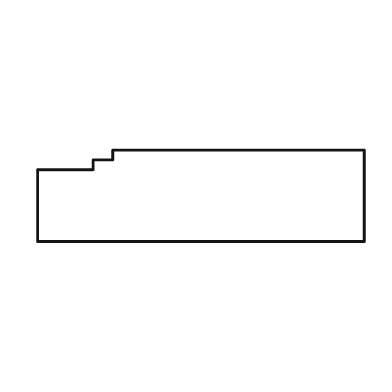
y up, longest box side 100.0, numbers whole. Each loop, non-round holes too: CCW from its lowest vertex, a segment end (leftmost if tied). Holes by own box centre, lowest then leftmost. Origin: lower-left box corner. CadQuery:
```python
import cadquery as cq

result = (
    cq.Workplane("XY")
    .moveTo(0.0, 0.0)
    .lineTo(100.0, 0.0)
    .lineTo(100.0, 28.0)
    .lineTo(23.0, 28.0)
    .lineTo(23.0, 25.0)
    .lineTo(17.0, 25.0)
    .lineTo(17.0, 22.0)
    .lineTo(0.0, 22.0)
    .close()
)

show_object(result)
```